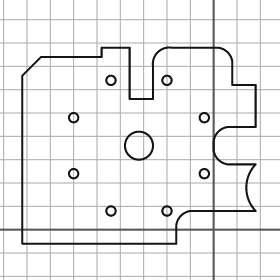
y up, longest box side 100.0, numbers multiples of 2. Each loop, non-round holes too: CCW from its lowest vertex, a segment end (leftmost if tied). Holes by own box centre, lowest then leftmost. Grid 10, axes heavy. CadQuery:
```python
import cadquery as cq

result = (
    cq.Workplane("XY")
    .moveTo(-82.0, -6.0)
    .lineTo(-16.0, -6.0)
    .lineTo(-16.0, 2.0)
    .threePointArc((-14.0, 6.0), (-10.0, 8.0))
    .lineTo(18.0, 8.0)
    .threePointArc((14.0, 18.0), (18.0, 28.0))
    .lineTo(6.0, 28.0)
    .threePointArc((2.0, 30.0), (0.0, 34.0))
    .lineTo(0.0, 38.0)
    .threePointArc((2.0, 42.0), (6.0, 44.0))
    .lineTo(18.0, 44.0)
    .lineTo(18.0, 62.0)
    .lineTo(8.0, 62.0)
    .lineTo(8.0, 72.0)
    .threePointArc((6.0, 76.0), (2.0, 78.0))
    .lineTo(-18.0, 78.0)
    .threePointArc((-24.0, 76.0), (-26.0, 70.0))
    .lineTo(-26.0, 56.0)
    .lineTo(-36.0, 56.0)
    .lineTo(-36.0, 78.0)
    .lineTo(-48.0, 78.0)
    .lineTo(-48.0, 74.0)
    .lineTo(-74.0, 74.0)
    .lineTo(-82.0, 66.0)
    .close()
    .moveTo(-44.0, 8.0)
    .circle(2.0)
    .moveTo(-20.0, 8.0)
    .circle(2.0)
    .moveTo(-60.0, 24.0)
    .circle(2.0)
    .moveTo(-4.0, 24.0)
    .circle(2.0)
    .moveTo(-32.0, 36.0)
    .circle(6.0)
    .moveTo(-60.0, 48.0)
    .circle(2.0)
    .moveTo(-4.0, 48.0)
    .circle(2.0)
    .moveTo(-44.0, 64.0)
    .circle(2.0)
    .moveTo(-20.0, 64.0)
    .circle(2.0)
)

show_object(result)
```